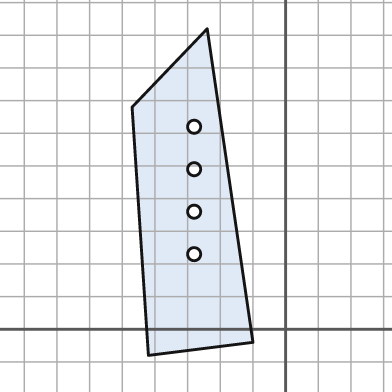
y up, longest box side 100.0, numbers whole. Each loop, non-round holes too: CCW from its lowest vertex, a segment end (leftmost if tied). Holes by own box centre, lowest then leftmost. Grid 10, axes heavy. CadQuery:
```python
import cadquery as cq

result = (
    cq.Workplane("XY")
    .moveTo(-42.0, -8.0)
    .lineTo(-10.0, -4.0)
    .lineTo(-24.0, 92.0)
    .lineTo(-47.0, 68.0)
    .close()
    .moveTo(-28.0, 23.0)
    .circle(2.0)
    .moveTo(-28.0, 36.0)
    .circle(2.0)
    .moveTo(-28.0, 49.0)
    .circle(2.0)
    .moveTo(-28.0, 62.0)
    .circle(2.0)
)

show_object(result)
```